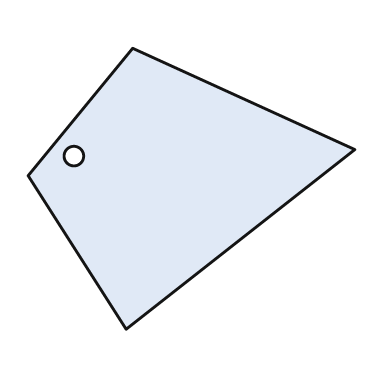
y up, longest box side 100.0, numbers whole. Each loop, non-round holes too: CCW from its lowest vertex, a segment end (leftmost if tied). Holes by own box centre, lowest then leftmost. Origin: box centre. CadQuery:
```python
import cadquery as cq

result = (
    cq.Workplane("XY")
    .moveTo(-20.0, -43.0)
    .lineTo(50.0, 12.0)
    .lineTo(-18.0, 43.0)
    .lineTo(-50.0, 4.0)
    .close()
    .moveTo(-36.0, 10.0)
    .circle(3.0)
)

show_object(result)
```